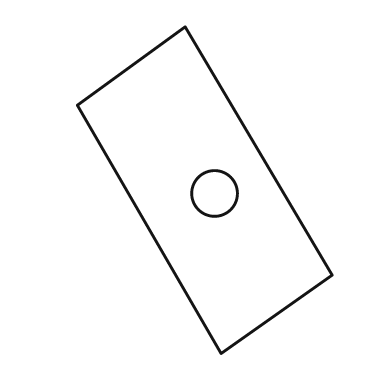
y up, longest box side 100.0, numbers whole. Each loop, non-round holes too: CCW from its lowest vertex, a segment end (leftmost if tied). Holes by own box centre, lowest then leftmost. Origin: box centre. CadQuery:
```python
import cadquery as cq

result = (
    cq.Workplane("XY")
    .moveTo(5.0, -50.0)
    .lineTo(39.0, -26.0)
    .lineTo(-6.0, 50.0)
    .lineTo(-39.0, 26.0)
    .close()
    .moveTo(3.0, -1.0)
    .circle(7.0)
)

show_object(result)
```